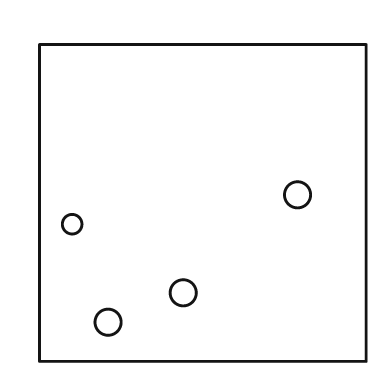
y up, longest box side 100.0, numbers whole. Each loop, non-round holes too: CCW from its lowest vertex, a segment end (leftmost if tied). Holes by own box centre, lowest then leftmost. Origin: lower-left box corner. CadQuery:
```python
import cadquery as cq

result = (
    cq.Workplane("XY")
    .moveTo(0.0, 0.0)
    .lineTo(100.0, 0.0)
    .lineTo(100.0, 97.0)
    .lineTo(0.0, 97.0)
    .close()
    .moveTo(21.0, 12.0)
    .circle(4.0)
    .moveTo(44.0, 21.0)
    .circle(4.0)
    .moveTo(10.0, 42.0)
    .circle(3.0)
    .moveTo(79.0, 51.0)
    .circle(4.0)
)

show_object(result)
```